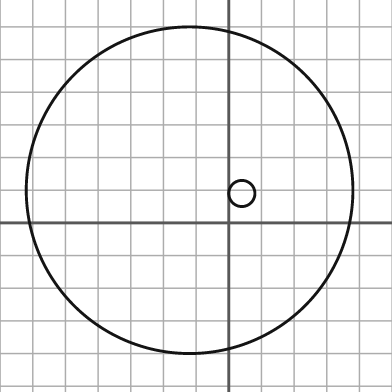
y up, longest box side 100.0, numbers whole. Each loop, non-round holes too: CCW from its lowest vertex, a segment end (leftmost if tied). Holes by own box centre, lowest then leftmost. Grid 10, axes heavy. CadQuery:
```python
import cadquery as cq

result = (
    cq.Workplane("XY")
    .moveTo(-12.0, 10.0)
    .circle(50.0)
    .moveTo(4.0, 9.0)
    .circle(4.0)
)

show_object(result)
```